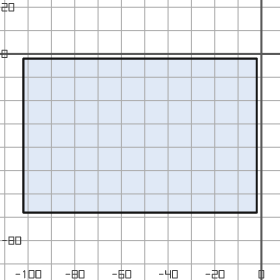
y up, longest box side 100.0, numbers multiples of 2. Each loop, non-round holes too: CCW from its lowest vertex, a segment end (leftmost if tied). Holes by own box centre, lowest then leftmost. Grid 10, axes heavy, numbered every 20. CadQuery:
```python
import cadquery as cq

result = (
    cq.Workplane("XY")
    .moveTo(-102.0, -68.0)
    .lineTo(-2.0, -68.0)
    .lineTo(-2.0, -2.0)
    .lineTo(-102.0, -2.0)
    .close()
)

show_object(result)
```